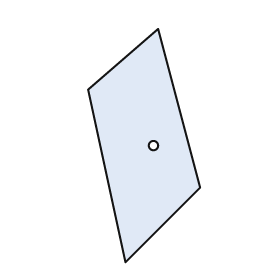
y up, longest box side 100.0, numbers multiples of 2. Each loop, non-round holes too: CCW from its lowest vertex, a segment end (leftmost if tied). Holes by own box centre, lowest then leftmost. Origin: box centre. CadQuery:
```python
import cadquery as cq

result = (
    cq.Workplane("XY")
    .moveTo(-8.0, -50.0)
    .lineTo(24.0, -18.0)
    .lineTo(6.0, 50.0)
    .lineTo(-24.0, 24.0)
    .close()
    .moveTo(4.0, 0.0)
    .circle(2.0)
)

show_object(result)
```